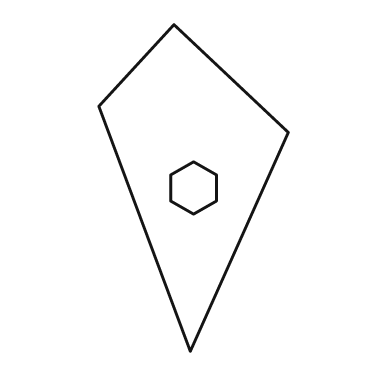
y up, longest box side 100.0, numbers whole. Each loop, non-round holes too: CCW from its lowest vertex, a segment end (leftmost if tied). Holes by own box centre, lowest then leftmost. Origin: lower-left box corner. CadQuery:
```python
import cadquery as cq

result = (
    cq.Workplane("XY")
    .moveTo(28.0, 0.0)
    .lineTo(58.0, 67.0)
    .lineTo(23.0, 100.0)
    .lineTo(0.0, 75.0)
    .close()
    .moveTo(29.0, 42.0)
    .lineTo(36.0, 46.0)
    .lineTo(36.0, 54.0)
    .lineTo(29.0, 58.0)
    .lineTo(22.0, 54.0)
    .lineTo(22.0, 46.0)
    .close()
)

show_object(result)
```